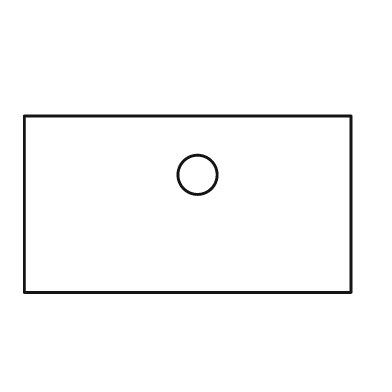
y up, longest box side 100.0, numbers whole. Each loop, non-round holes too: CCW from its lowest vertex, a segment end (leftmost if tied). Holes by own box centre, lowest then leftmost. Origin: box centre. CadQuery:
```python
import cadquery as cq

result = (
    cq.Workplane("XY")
    .moveTo(-50.0, -27.0)
    .lineTo(50.0, -27.0)
    .lineTo(50.0, 27.0)
    .lineTo(-50.0, 27.0)
    .close()
    .moveTo(3.0, 9.0)
    .circle(6.0)
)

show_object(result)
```